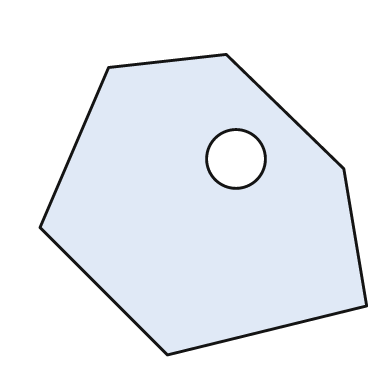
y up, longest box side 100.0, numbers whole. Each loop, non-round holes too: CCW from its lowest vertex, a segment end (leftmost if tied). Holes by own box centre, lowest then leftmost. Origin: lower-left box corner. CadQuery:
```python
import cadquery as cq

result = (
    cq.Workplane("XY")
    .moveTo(39.0, 0.0)
    .lineTo(100.0, 15.0)
    .lineTo(93.0, 57.0)
    .lineTo(57.0, 92.0)
    .lineTo(21.0, 88.0)
    .lineTo(0.0, 39.0)
    .close()
    .moveTo(60.0, 60.0)
    .circle(9.0)
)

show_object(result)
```